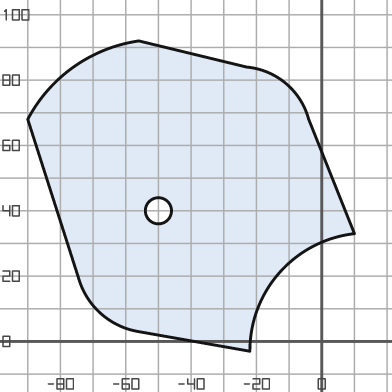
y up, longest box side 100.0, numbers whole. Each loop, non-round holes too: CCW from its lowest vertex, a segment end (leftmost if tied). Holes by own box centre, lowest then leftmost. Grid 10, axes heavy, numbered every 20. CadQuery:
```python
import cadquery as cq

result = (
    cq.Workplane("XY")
    .moveTo(-22.0, -3.0)
    .threePointArc((-13.0, 21.0), (10.0, 33.0))
    .lineTo(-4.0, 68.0)
    .threePointArc((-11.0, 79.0), (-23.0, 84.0))
    .lineTo(-56.0, 92.0)
    .threePointArc((-76.0, 84.0), (-90.0, 68.0))
    .lineTo(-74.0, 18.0)
    .threePointArc((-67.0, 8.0), (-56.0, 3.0))
    .close()
    .moveTo(-50.0, 40.0)
    .circle(4.0)
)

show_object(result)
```